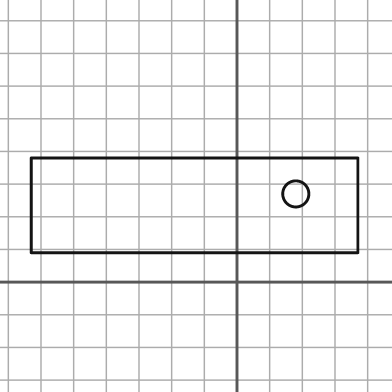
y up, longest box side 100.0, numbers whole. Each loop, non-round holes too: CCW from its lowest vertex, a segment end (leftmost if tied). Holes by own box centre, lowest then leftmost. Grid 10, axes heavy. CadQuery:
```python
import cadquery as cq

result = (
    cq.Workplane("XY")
    .moveTo(-63.0, 9.0)
    .lineTo(37.0, 9.0)
    .lineTo(37.0, 38.0)
    .lineTo(-63.0, 38.0)
    .close()
    .moveTo(18.0, 27.0)
    .circle(4.0)
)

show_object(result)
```